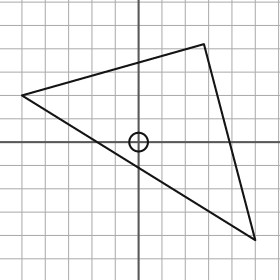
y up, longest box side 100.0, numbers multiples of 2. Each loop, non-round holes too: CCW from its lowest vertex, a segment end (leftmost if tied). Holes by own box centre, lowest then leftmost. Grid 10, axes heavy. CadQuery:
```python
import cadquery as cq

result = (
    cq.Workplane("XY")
    .moveTo(50.0, -42.0)
    .lineTo(28.0, 42.0)
    .lineTo(-50.0, 20.0)
    .close()
    .moveTo(0.0, 0.0)
    .circle(4.0)
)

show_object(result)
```